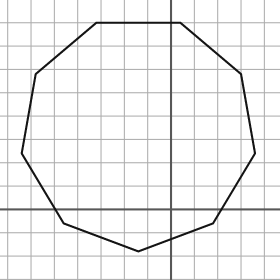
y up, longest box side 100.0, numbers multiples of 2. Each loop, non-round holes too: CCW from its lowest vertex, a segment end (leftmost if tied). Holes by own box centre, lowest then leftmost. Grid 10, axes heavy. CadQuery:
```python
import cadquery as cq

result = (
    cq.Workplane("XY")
    .moveTo(-14.0, -18.0)
    .lineTo(18.0, -6.0)
    .lineTo(36.0, 24.0)
    .lineTo(30.0, 58.0)
    .lineTo(4.0, 80.0)
    .lineTo(-32.0, 80.0)
    .lineTo(-58.0, 58.0)
    .lineTo(-64.0, 24.0)
    .lineTo(-46.0, -6.0)
    .close()
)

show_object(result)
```